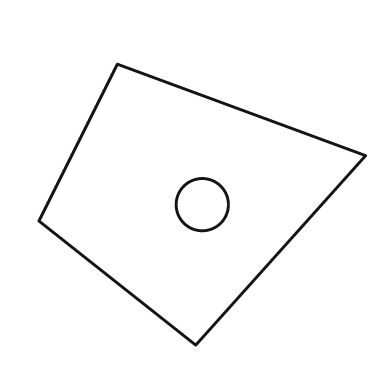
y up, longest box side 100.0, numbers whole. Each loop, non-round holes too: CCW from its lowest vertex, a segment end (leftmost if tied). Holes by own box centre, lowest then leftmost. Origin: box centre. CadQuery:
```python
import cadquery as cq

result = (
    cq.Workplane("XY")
    .moveTo(-2.0, -43.0)
    .lineTo(50.0, 15.0)
    .lineTo(-26.0, 43.0)
    .lineTo(-50.0, -5.0)
    .close()
    .moveTo(0.0, 0.0)
    .circle(8.0)
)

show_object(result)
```